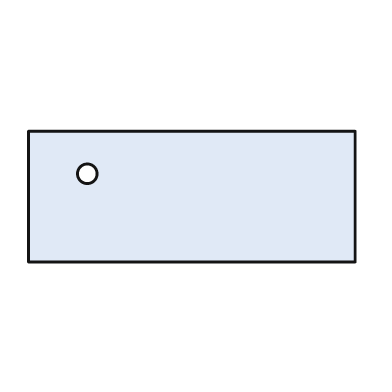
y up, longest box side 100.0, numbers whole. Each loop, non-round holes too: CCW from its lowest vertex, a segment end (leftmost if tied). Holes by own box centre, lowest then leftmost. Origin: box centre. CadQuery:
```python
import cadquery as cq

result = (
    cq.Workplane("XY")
    .moveTo(-50.0, -20.0)
    .lineTo(50.0, -20.0)
    .lineTo(50.0, 20.0)
    .lineTo(-50.0, 20.0)
    .close()
    .moveTo(-32.0, 7.0)
    .circle(3.0)
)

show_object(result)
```